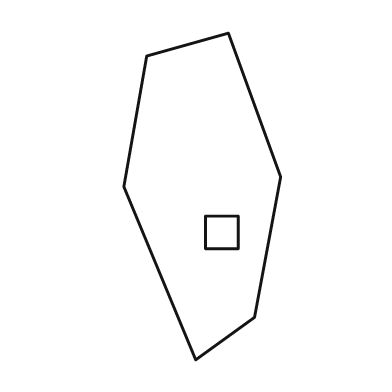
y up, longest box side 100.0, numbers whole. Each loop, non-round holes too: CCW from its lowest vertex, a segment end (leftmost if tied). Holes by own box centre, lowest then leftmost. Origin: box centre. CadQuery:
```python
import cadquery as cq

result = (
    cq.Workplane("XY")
    .moveTo(-2.0, -50.0)
    .lineTo(16.0, -37.0)
    .lineTo(24.0, 6.0)
    .lineTo(8.0, 50.0)
    .lineTo(-17.0, 43.0)
    .lineTo(-24.0, 3.0)
    .close()
    .moveTo(1.0, -16.0)
    .lineTo(11.0, -16.0)
    .lineTo(11.0, -6.0)
    .lineTo(1.0, -6.0)
    .close()
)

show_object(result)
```